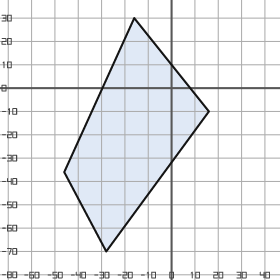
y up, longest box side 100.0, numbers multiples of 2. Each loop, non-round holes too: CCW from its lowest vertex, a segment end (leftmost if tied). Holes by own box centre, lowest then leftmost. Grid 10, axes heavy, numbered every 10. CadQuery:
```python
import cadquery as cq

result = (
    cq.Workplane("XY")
    .moveTo(-28.0, -70.0)
    .lineTo(16.0, -10.0)
    .lineTo(-16.0, 30.0)
    .lineTo(-46.0, -36.0)
    .close()
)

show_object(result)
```